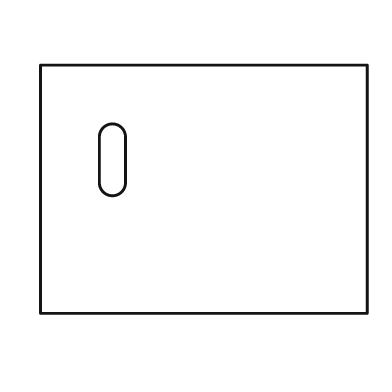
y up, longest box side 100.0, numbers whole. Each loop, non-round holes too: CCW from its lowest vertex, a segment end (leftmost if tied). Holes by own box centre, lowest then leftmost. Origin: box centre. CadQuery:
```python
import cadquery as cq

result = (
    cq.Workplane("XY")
    .moveTo(-50.0, -38.0)
    .lineTo(50.0, -38.0)
    .lineTo(50.0, 38.0)
    .lineTo(-50.0, 38.0)
    .close()
    .moveTo(-32.0, 2.0)
    .threePointArc((-28.0, -2.0), (-24.0, 2.0))
    .lineTo(-24.0, 16.0)
    .threePointArc((-28.0, 20.0), (-32.0, 16.0))
    .close()
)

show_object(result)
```